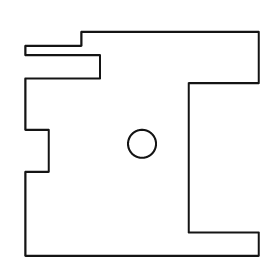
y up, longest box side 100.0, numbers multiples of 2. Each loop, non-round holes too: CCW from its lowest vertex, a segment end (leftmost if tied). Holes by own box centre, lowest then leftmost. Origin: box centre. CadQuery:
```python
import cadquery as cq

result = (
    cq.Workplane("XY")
    .moveTo(-50.0, -48.0)
    .lineTo(50.0, -48.0)
    .lineTo(50.0, -38.0)
    .lineTo(20.0, -38.0)
    .lineTo(20.0, 26.0)
    .lineTo(50.0, 26.0)
    .lineTo(50.0, 48.0)
    .lineTo(-26.0, 48.0)
    .lineTo(-26.0, 42.0)
    .lineTo(-50.0, 42.0)
    .lineTo(-50.0, 38.0)
    .lineTo(-18.0, 38.0)
    .lineTo(-18.0, 28.0)
    .lineTo(-50.0, 28.0)
    .lineTo(-50.0, 6.0)
    .lineTo(-40.0, 6.0)
    .lineTo(-40.0, -12.0)
    .lineTo(-50.0, -12.0)
    .close()
    .moveTo(0.0, 0.0)
    .circle(6.0)
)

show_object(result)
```